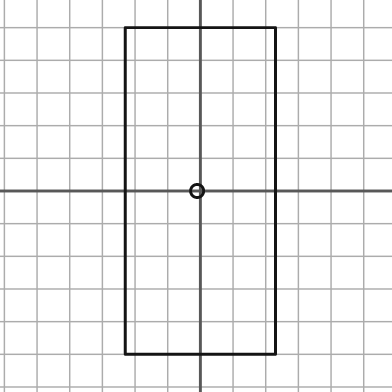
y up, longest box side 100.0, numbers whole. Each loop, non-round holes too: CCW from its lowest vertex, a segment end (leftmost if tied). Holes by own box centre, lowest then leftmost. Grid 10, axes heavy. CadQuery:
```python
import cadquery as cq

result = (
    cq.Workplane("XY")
    .moveTo(-23.0, -50.0)
    .lineTo(23.0, -50.0)
    .lineTo(23.0, 50.0)
    .lineTo(-23.0, 50.0)
    .close()
    .moveTo(-1.0, 0.0)
    .circle(2.0)
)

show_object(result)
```